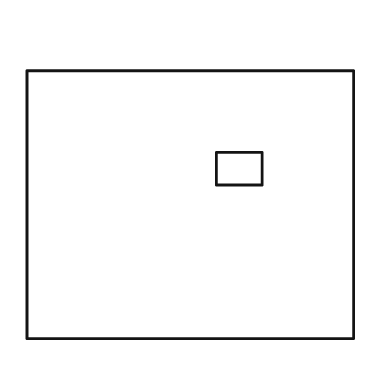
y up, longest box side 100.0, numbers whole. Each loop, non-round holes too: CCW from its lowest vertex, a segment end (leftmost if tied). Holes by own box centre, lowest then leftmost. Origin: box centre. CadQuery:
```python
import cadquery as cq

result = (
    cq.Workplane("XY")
    .moveTo(-50.0, -41.0)
    .lineTo(50.0, -41.0)
    .lineTo(50.0, 41.0)
    .lineTo(-50.0, 41.0)
    .close()
    .moveTo(8.0, 6.0)
    .lineTo(22.0, 6.0)
    .lineTo(22.0, 16.0)
    .lineTo(8.0, 16.0)
    .close()
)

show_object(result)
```